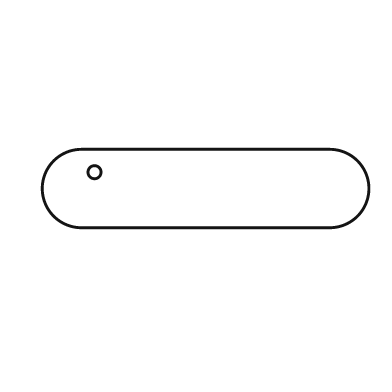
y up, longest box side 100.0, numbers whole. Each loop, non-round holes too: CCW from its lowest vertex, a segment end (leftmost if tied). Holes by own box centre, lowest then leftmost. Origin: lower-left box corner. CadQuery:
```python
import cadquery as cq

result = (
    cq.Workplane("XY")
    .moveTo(12.0, 0.0)
    .lineTo(88.0, 0.0)
    .threePointArc((100.0, 12.0), (88.0, 24.0))
    .lineTo(12.0, 24.0)
    .threePointArc((0.0, 12.0), (12.0, 0.0))
    .close()
    .moveTo(16.0, 17.0)
    .circle(2.0)
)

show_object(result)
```